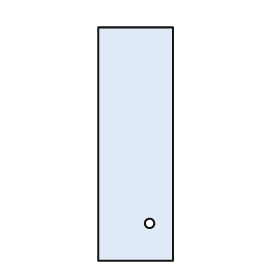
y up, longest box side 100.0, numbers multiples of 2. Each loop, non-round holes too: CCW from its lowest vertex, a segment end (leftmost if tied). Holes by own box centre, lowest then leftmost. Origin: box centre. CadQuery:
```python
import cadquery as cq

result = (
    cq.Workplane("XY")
    .moveTo(-16.0, -50.0)
    .lineTo(16.0, -50.0)
    .lineTo(16.0, 50.0)
    .lineTo(-16.0, 50.0)
    .close()
    .moveTo(6.0, -34.0)
    .circle(2.0)
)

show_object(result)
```